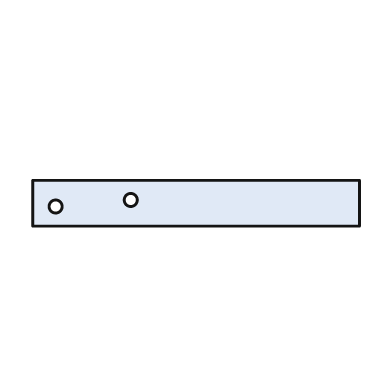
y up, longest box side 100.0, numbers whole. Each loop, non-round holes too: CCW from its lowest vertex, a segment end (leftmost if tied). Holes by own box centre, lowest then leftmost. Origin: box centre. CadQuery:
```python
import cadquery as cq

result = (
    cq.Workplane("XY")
    .moveTo(-50.0, -7.0)
    .lineTo(50.0, -7.0)
    .lineTo(50.0, 7.0)
    .lineTo(-50.0, 7.0)
    .close()
    .moveTo(-43.0, -1.0)
    .circle(2.0)
    .moveTo(-20.0, 1.0)
    .circle(2.0)
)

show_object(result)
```